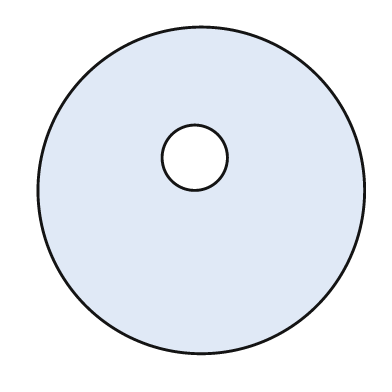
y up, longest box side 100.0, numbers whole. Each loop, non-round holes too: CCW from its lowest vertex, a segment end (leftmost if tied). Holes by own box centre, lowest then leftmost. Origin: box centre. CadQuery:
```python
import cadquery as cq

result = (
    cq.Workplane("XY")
    .moveTo(0.0, 0.0)
    .circle(50.0)
    .moveTo(-2.0, 10.0)
    .circle(10.0)
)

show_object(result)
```